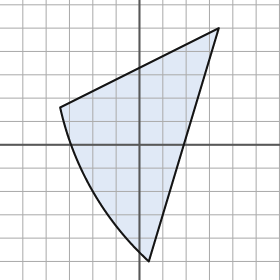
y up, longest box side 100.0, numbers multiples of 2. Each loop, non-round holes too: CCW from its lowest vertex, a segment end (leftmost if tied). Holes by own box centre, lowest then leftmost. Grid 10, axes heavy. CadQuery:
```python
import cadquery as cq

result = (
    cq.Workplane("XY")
    .moveTo(4.0, -50.0)
    .lineTo(34.0, 50.0)
    .lineTo(-34.0, 16.0)
    .threePointArc((-20.0, -20.0), (4.0, -50.0))
    .close()
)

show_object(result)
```